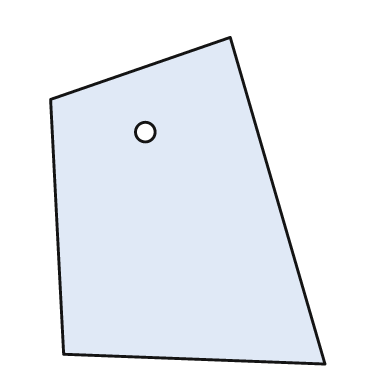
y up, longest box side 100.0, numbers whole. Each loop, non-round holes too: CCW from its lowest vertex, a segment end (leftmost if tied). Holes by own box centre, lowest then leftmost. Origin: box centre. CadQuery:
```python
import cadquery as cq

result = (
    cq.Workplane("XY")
    .moveTo(42.0, -50.0)
    .lineTo(13.0, 50.0)
    .lineTo(-42.0, 31.0)
    .lineTo(-38.0, -47.0)
    .close()
    .moveTo(-13.0, 21.0)
    .circle(3.0)
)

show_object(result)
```